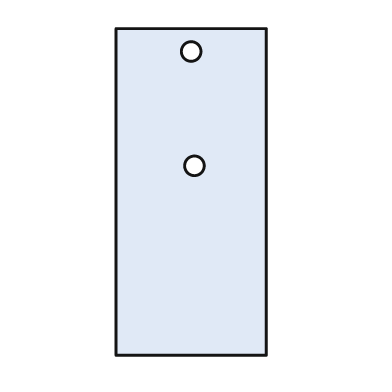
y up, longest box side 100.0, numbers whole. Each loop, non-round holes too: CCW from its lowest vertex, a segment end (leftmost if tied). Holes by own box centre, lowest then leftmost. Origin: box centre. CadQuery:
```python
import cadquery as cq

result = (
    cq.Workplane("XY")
    .moveTo(-23.0, -50.0)
    .lineTo(23.0, -50.0)
    .lineTo(23.0, 50.0)
    .lineTo(-23.0, 50.0)
    .close()
    .moveTo(1.0, 8.0)
    .circle(3.0)
    .moveTo(0.0, 43.0)
    .circle(3.0)
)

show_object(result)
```